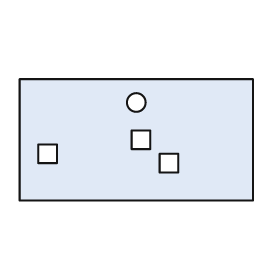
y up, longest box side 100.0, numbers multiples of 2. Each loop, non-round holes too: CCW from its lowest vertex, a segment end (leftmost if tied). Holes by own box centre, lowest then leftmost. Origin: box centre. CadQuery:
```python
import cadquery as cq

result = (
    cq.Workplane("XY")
    .moveTo(-50.0, -26.0)
    .lineTo(50.0, -26.0)
    .lineTo(50.0, 26.0)
    .lineTo(-50.0, 26.0)
    .close()
    .moveTo(10.0, -14.0)
    .lineTo(18.0, -14.0)
    .lineTo(18.0, -6.0)
    .lineTo(10.0, -6.0)
    .close()
    .moveTo(-42.0, -10.0)
    .lineTo(-34.0, -10.0)
    .lineTo(-34.0, -2.0)
    .lineTo(-42.0, -2.0)
    .close()
    .moveTo(-2.0, -4.0)
    .lineTo(6.0, -4.0)
    .lineTo(6.0, 4.0)
    .lineTo(-2.0, 4.0)
    .close()
    .moveTo(0.0, 16.0)
    .circle(4.0)
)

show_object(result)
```